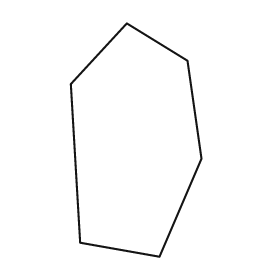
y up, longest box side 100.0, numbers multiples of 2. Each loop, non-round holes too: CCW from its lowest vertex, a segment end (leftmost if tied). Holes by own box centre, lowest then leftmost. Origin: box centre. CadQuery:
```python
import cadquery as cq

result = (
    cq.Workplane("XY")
    .moveTo(10.0, -50.0)
    .lineTo(28.0, -8.0)
    .lineTo(22.0, 34.0)
    .lineTo(-4.0, 50.0)
    .lineTo(-28.0, 24.0)
    .lineTo(-24.0, -44.0)
    .close()
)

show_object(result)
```